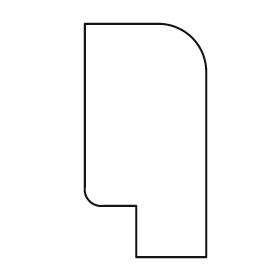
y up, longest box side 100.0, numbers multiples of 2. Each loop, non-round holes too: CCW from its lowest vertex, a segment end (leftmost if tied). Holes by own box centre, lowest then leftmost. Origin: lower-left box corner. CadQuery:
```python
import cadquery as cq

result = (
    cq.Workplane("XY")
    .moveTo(22.0, 0.0)
    .lineTo(52.0, 0.0)
    .lineTo(52.0, 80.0)
    .threePointArc((46.0, 94.0), (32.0, 100.0))
    .lineTo(0.0, 100.0)
    .lineTo(0.0, 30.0)
    .threePointArc((2.0, 24.0), (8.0, 22.0))
    .lineTo(22.0, 22.0)
    .close()
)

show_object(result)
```